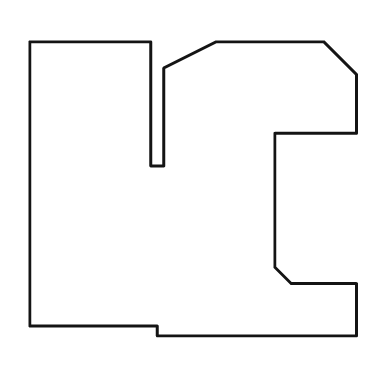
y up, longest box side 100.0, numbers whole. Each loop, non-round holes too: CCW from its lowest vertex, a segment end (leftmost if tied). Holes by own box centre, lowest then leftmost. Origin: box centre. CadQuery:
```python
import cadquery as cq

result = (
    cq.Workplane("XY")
    .moveTo(-11.0, -45.0)
    .lineTo(50.0, -45.0)
    .lineTo(50.0, -29.0)
    .lineTo(30.0, -29.0)
    .lineTo(25.0, -24.0)
    .lineTo(25.0, 17.0)
    .lineTo(50.0, 17.0)
    .lineTo(50.0, 35.0)
    .lineTo(40.0, 45.0)
    .lineTo(7.0, 45.0)
    .lineTo(-9.0, 37.0)
    .lineTo(-9.0, 7.0)
    .lineTo(-13.0, 7.0)
    .lineTo(-13.0, 45.0)
    .lineTo(-50.0, 45.0)
    .lineTo(-50.0, -42.0)
    .lineTo(-11.0, -42.0)
    .close()
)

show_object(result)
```